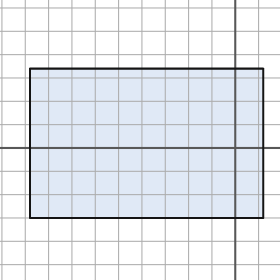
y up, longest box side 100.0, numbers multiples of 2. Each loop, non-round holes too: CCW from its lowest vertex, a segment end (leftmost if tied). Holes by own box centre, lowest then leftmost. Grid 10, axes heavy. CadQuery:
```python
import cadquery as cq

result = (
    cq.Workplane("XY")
    .moveTo(-88.0, -30.0)
    .lineTo(12.0, -30.0)
    .lineTo(12.0, 34.0)
    .lineTo(-88.0, 34.0)
    .close()
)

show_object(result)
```